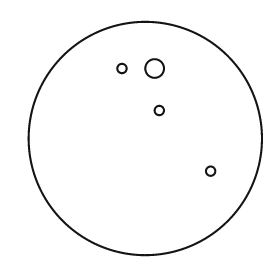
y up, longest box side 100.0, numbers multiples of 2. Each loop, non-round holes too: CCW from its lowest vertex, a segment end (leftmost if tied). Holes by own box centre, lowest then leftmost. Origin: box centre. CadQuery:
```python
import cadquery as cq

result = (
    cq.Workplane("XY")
    .moveTo(0.0, 0.0)
    .circle(50.0)
    .moveTo(28.0, -14.0)
    .circle(2.0)
    .moveTo(6.0, 12.0)
    .circle(2.0)
    .moveTo(-10.0, 30.0)
    .circle(2.0)
    .moveTo(4.0, 30.0)
    .circle(4.0)
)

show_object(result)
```